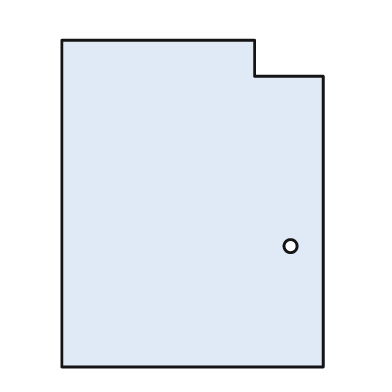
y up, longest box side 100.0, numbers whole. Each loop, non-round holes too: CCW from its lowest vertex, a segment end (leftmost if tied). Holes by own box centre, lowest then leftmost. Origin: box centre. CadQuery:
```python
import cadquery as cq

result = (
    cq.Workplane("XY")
    .moveTo(-40.0, -50.0)
    .lineTo(40.0, -50.0)
    .lineTo(40.0, 39.0)
    .lineTo(19.0, 39.0)
    .lineTo(19.0, 50.0)
    .lineTo(-40.0, 50.0)
    .close()
    .moveTo(30.0, -13.0)
    .circle(2.0)
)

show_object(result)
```